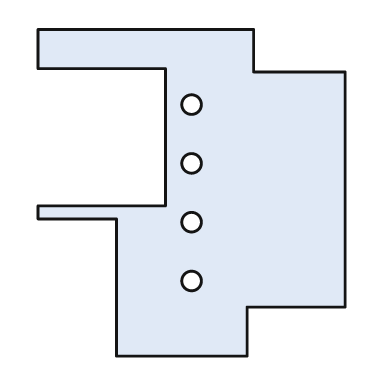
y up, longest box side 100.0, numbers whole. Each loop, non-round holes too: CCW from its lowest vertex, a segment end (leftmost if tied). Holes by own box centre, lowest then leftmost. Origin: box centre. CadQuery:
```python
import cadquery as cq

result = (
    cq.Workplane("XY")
    .moveTo(-23.0, -50.0)
    .lineTo(17.0, -50.0)
    .lineTo(17.0, -35.0)
    .lineTo(47.0, -35.0)
    .lineTo(47.0, 37.0)
    .lineTo(19.0, 37.0)
    .lineTo(19.0, 50.0)
    .lineTo(-47.0, 50.0)
    .lineTo(-47.0, 38.0)
    .lineTo(-8.0, 38.0)
    .lineTo(-8.0, -4.0)
    .lineTo(-47.0, -4.0)
    .lineTo(-47.0, -8.0)
    .lineTo(-23.0, -8.0)
    .close()
    .moveTo(0.0, -27.0)
    .circle(3.0)
    .moveTo(0.0, -9.0)
    .circle(3.0)
    .moveTo(0.0, 9.0)
    .circle(3.0)
    .moveTo(0.0, 27.0)
    .circle(3.0)
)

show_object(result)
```